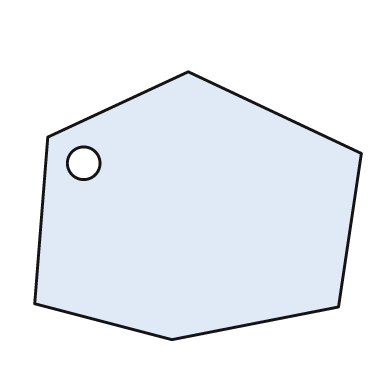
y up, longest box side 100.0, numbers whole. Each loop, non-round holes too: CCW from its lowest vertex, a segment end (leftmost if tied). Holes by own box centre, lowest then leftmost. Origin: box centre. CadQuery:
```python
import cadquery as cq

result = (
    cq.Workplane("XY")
    .moveTo(-8.0, -41.0)
    .lineTo(43.0, -31.0)
    .lineTo(50.0, 16.0)
    .lineTo(-3.0, 41.0)
    .lineTo(-46.0, 21.0)
    .lineTo(-50.0, -30.0)
    .close()
    .moveTo(-35.0, 13.0)
    .circle(5.0)
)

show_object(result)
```